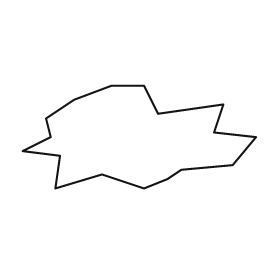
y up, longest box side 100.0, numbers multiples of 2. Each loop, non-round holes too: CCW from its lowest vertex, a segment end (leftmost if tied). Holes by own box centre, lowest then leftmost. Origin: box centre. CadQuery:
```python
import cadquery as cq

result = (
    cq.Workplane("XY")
    .moveTo(-36.0, -22.0)
    .lineTo(-16.0, -16.0)
    .lineTo(2.0, -22.0)
    .lineTo(12.0, -18.0)
    .lineTo(18.0, -14.0)
    .lineTo(40.0, -12.0)
    .lineTo(50.0, 0.0)
    .lineTo(32.0, 2.0)
    .lineTo(36.0, 14.0)
    .lineTo(8.0, 10.0)
    .lineTo(2.0, 22.0)
    .lineTo(-12.0, 22.0)
    .lineTo(-28.0, 16.0)
    .lineTo(-40.0, 8.0)
    .lineTo(-38.0, 0.0)
    .lineTo(-50.0, -6.0)
    .lineTo(-34.0, -8.0)
    .close()
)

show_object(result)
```